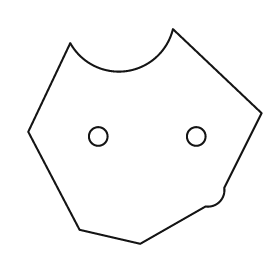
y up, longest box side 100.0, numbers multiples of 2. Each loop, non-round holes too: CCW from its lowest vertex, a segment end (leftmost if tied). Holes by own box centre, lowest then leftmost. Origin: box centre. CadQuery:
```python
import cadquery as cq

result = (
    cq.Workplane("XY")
    .moveTo(-2.0, -46.0)
    .lineTo(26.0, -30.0)
    .threePointArc((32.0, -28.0), (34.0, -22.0))
    .lineTo(50.0, 10.0)
    .lineTo(12.0, 46.0)
    .threePointArc((-8.0, 28.0), (-32.0, 40.0))
    .lineTo(-50.0, 2.0)
    .lineTo(-28.0, -40.0)
    .close()
    .moveTo(-20.0, 0.0)
    .circle(4.0)
    .moveTo(22.0, 0.0)
    .circle(4.0)
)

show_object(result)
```